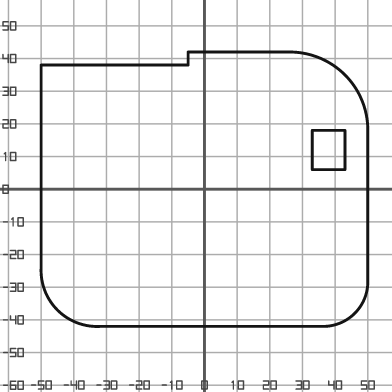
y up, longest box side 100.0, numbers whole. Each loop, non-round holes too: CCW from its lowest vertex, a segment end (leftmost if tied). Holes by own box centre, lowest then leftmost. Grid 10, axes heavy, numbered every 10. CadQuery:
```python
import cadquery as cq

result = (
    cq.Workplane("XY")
    .moveTo(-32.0, -42.0)
    .lineTo(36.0, -42.0)
    .threePointArc((46.0, -38.0), (50.0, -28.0))
    .lineTo(50.0, 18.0)
    .threePointArc((43.0, 35.0), (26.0, 42.0))
    .lineTo(-5.0, 42.0)
    .lineTo(-5.0, 38.0)
    .lineTo(-50.0, 38.0)
    .lineTo(-50.0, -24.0)
    .threePointArc((-45.0, -37.0), (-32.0, -42.0))
    .close()
    .moveTo(33.0, 6.0)
    .lineTo(43.0, 6.0)
    .lineTo(43.0, 18.0)
    .lineTo(33.0, 18.0)
    .close()
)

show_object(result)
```